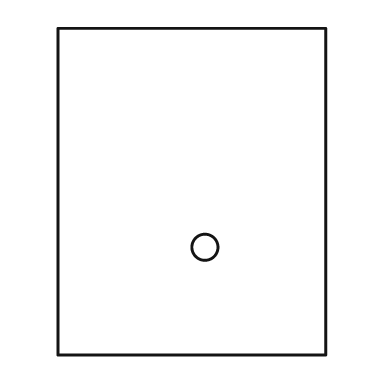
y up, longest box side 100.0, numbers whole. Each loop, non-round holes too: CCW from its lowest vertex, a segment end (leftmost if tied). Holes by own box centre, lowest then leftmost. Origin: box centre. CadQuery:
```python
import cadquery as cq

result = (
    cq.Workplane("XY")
    .moveTo(-41.0, -50.0)
    .lineTo(41.0, -50.0)
    .lineTo(41.0, 50.0)
    .lineTo(-41.0, 50.0)
    .close()
    .moveTo(4.0, -17.0)
    .circle(4.0)
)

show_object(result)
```